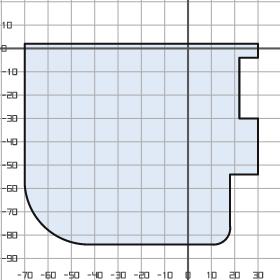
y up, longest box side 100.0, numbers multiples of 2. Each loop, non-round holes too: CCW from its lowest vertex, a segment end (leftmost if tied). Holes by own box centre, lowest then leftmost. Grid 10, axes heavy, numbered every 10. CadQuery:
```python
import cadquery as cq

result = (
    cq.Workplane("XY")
    .moveTo(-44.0, -84.0)
    .lineTo(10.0, -84.0)
    .threePointArc((16.0, -82.0), (18.0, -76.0))
    .lineTo(18.0, -54.0)
    .lineTo(30.0, -54.0)
    .lineTo(30.0, -30.0)
    .lineTo(22.0, -30.0)
    .lineTo(22.0, -4.0)
    .lineTo(30.0, -4.0)
    .lineTo(30.0, 2.0)
    .lineTo(-70.0, 2.0)
    .lineTo(-70.0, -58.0)
    .threePointArc((-62.0, -76.0), (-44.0, -84.0))
    .close()
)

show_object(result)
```